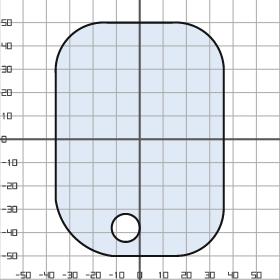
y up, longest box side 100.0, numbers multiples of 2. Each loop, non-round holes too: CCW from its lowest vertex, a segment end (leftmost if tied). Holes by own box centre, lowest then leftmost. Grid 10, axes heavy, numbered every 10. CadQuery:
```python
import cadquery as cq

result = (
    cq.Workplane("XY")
    .moveTo(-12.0, -50.0)
    .lineTo(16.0, -50.0)
    .threePointArc((30.0, -44.0), (36.0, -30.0))
    .lineTo(36.0, 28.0)
    .threePointArc((30.0, 44.0), (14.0, 50.0))
    .lineTo(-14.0, 50.0)
    .threePointArc((-30.0, 44.0), (-36.0, 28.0))
    .lineTo(-36.0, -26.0)
    .threePointArc((-28.0, -42.0), (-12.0, -50.0))
    .close()
    .moveTo(-6.0, -38.0)
    .circle(6.0)
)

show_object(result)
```